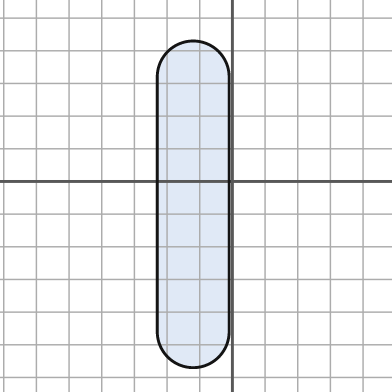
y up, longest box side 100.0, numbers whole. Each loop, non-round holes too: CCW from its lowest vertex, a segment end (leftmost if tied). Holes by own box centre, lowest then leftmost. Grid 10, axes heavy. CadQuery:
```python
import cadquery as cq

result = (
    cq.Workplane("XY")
    .moveTo(-23.0, -46.0)
    .threePointArc((-12.0, -57.0), (-1.0, -46.0))
    .lineTo(-1.0, 32.0)
    .threePointArc((-12.0, 43.0), (-23.0, 32.0))
    .close()
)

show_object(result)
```